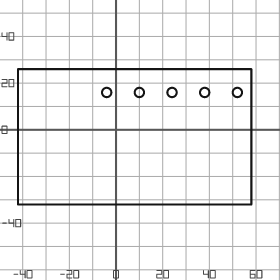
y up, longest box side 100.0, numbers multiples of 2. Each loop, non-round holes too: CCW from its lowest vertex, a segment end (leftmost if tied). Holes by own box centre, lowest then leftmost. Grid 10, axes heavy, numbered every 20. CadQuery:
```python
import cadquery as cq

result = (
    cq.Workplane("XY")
    .moveTo(-42.0, -32.0)
    .lineTo(58.0, -32.0)
    .lineTo(58.0, 26.0)
    .lineTo(-42.0, 26.0)
    .close()
    .moveTo(-4.0, 16.0)
    .circle(2.0)
    .moveTo(10.0, 16.0)
    .circle(2.0)
    .moveTo(24.0, 16.0)
    .circle(2.0)
    .moveTo(38.0, 16.0)
    .circle(2.0)
    .moveTo(52.0, 16.0)
    .circle(2.0)
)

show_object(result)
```